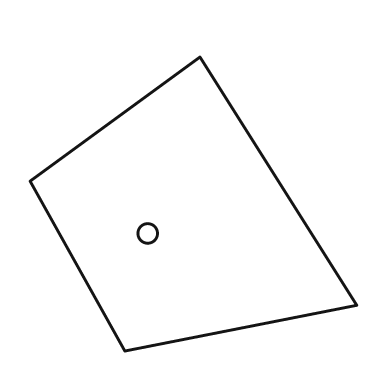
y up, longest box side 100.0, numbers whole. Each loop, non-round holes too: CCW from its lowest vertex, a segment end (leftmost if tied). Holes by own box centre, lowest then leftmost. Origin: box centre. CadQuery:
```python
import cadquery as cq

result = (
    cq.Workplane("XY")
    .moveTo(-21.0, -45.0)
    .lineTo(50.0, -31.0)
    .lineTo(2.0, 45.0)
    .lineTo(-50.0, 7.0)
    .close()
    .moveTo(-14.0, -9.0)
    .circle(3.0)
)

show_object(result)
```